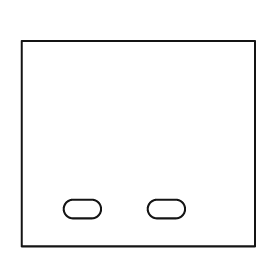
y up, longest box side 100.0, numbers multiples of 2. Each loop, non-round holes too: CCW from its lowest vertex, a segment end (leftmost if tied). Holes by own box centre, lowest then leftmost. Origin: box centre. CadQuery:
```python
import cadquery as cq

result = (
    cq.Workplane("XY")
    .moveTo(-50.0, -44.0)
    .lineTo(50.0, -44.0)
    .lineTo(50.0, 44.0)
    .lineTo(-50.0, 44.0)
    .close()
    .moveTo(-28.0, -32.0)
    .lineTo(-20.0, -32.0)
    .threePointArc((-16.0, -28.0), (-20.0, -24.0))
    .lineTo(-28.0, -24.0)
    .threePointArc((-32.0, -28.0), (-28.0, -32.0))
    .close()
    .moveTo(8.0, -32.0)
    .lineTo(16.0, -32.0)
    .threePointArc((20.0, -28.0), (16.0, -24.0))
    .lineTo(8.0, -24.0)
    .threePointArc((4.0, -28.0), (8.0, -32.0))
    .close()
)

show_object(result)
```